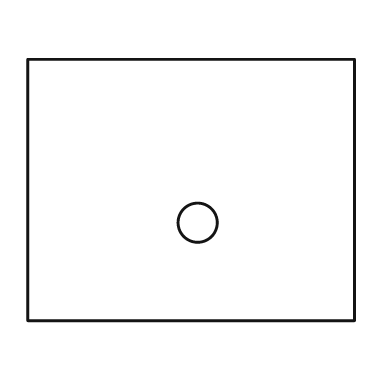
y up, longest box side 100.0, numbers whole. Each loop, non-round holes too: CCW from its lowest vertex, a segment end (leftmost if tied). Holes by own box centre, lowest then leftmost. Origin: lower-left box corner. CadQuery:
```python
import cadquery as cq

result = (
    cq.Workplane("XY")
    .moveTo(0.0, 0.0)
    .lineTo(100.0, 0.0)
    .lineTo(100.0, 80.0)
    .lineTo(0.0, 80.0)
    .close()
    .moveTo(52.0, 30.0)
    .circle(6.0)
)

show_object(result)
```